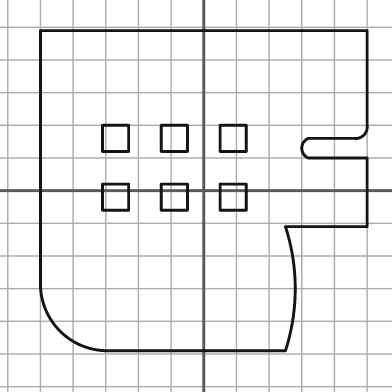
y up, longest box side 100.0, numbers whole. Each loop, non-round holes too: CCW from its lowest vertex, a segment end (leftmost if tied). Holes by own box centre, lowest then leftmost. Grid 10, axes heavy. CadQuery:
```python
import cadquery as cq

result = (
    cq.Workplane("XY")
    .moveTo(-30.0, -49.0)
    .lineTo(25.0, -49.0)
    .threePointArc((28.0, -30.0), (25.0, -11.0))
    .lineTo(50.0, -11.0)
    .lineTo(50.0, 10.0)
    .lineTo(32.0, 10.0)
    .threePointArc((30.0, 13.0), (32.0, 16.0))
    .lineTo(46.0, 16.0)
    .threePointArc((49.0, 17.0), (50.0, 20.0))
    .lineTo(50.0, 49.0)
    .lineTo(-50.0, 49.0)
    .lineTo(-50.0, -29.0)
    .threePointArc((-44.0, -43.0), (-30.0, -49.0))
    .close()
    .moveTo(-31.0, -6.0)
    .lineTo(-23.0, -6.0)
    .lineTo(-23.0, 2.0)
    .lineTo(-31.0, 2.0)
    .close()
    .moveTo(-13.0, -6.0)
    .lineTo(-5.0, -6.0)
    .lineTo(-5.0, 2.0)
    .lineTo(-13.0, 2.0)
    .close()
    .moveTo(5.0, -6.0)
    .lineTo(13.0, -6.0)
    .lineTo(13.0, 2.0)
    .lineTo(5.0, 2.0)
    .close()
    .moveTo(-31.0, 12.0)
    .lineTo(-23.0, 12.0)
    .lineTo(-23.0, 20.0)
    .lineTo(-31.0, 20.0)
    .close()
    .moveTo(-13.0, 12.0)
    .lineTo(-5.0, 12.0)
    .lineTo(-5.0, 20.0)
    .lineTo(-13.0, 20.0)
    .close()
    .moveTo(5.0, 12.0)
    .lineTo(13.0, 12.0)
    .lineTo(13.0, 20.0)
    .lineTo(5.0, 20.0)
    .close()
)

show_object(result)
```